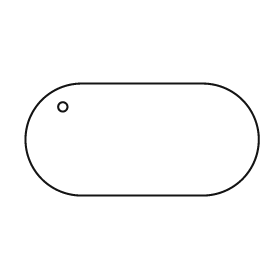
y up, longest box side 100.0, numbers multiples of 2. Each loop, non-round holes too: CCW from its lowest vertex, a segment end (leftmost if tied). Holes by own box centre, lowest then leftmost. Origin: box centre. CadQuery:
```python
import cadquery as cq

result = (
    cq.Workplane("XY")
    .moveTo(-26.0, -24.0)
    .lineTo(26.0, -24.0)
    .threePointArc((50.0, 0.0), (26.0, 24.0))
    .lineTo(-26.0, 24.0)
    .threePointArc((-50.0, 0.0), (-26.0, -24.0))
    .close()
    .moveTo(-34.0, 14.0)
    .circle(2.0)
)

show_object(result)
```